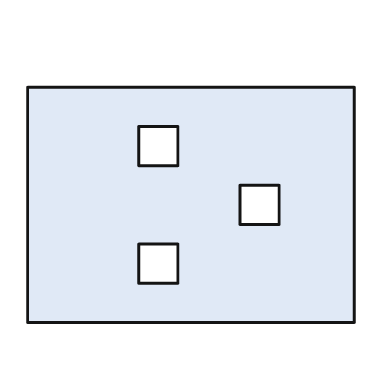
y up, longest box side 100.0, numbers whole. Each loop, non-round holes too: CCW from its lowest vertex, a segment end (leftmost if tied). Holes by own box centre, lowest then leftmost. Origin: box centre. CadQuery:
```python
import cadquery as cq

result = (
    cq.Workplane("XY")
    .moveTo(-50.0, -36.0)
    .lineTo(50.0, -36.0)
    .lineTo(50.0, 36.0)
    .lineTo(-50.0, 36.0)
    .close()
    .moveTo(-16.0, -24.0)
    .lineTo(-4.0, -24.0)
    .lineTo(-4.0, -12.0)
    .lineTo(-16.0, -12.0)
    .close()
    .moveTo(15.0, -6.0)
    .lineTo(27.0, -6.0)
    .lineTo(27.0, 6.0)
    .lineTo(15.0, 6.0)
    .close()
    .moveTo(-16.0, 12.0)
    .lineTo(-4.0, 12.0)
    .lineTo(-4.0, 24.0)
    .lineTo(-16.0, 24.0)
    .close()
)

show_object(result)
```